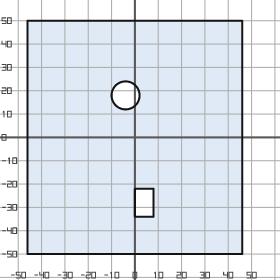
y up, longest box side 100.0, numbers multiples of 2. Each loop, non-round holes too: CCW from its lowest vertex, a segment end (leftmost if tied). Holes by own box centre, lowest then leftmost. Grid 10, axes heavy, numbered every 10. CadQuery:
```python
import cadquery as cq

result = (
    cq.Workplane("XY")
    .moveTo(-46.0, -50.0)
    .lineTo(46.0, -50.0)
    .lineTo(46.0, 50.0)
    .lineTo(-46.0, 50.0)
    .close()
    .moveTo(0.0, -34.0)
    .lineTo(8.0, -34.0)
    .lineTo(8.0, -22.0)
    .lineTo(0.0, -22.0)
    .close()
    .moveTo(-4.0, 18.0)
    .circle(6.0)
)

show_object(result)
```